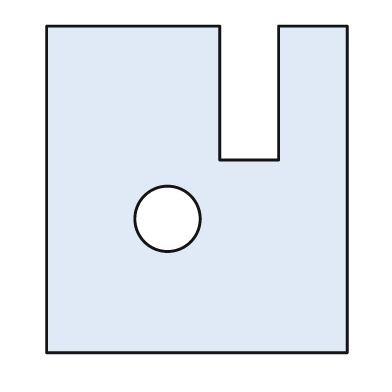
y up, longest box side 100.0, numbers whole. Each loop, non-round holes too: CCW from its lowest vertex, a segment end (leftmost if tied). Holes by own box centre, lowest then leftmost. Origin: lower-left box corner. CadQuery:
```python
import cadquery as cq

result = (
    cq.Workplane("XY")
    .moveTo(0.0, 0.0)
    .lineTo(92.0, 0.0)
    .lineTo(92.0, 100.0)
    .lineTo(71.0, 100.0)
    .lineTo(71.0, 59.0)
    .lineTo(53.0, 59.0)
    .lineTo(53.0, 100.0)
    .lineTo(0.0, 100.0)
    .close()
    .moveTo(37.0, 41.0)
    .circle(10.0)
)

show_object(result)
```